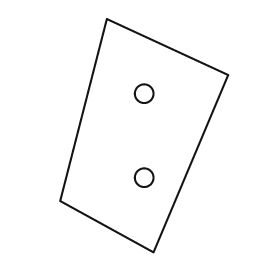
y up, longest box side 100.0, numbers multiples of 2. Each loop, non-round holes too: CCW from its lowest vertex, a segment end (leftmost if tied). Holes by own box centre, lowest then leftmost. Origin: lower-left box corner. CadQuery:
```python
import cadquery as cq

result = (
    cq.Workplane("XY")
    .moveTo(40.0, 0.0)
    .lineTo(72.0, 76.0)
    .lineTo(20.0, 100.0)
    .lineTo(0.0, 22.0)
    .close()
    .moveTo(36.0, 32.0)
    .circle(4.0)
    .moveTo(36.0, 68.0)
    .circle(4.0)
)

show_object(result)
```